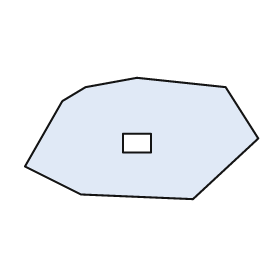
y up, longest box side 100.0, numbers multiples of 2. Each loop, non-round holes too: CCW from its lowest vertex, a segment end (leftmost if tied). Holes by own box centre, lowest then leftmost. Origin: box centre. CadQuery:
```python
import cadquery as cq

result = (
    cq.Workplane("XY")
    .moveTo(22.0, -26.0)
    .lineTo(50.0, 0.0)
    .lineTo(36.0, 22.0)
    .lineTo(-2.0, 26.0)
    .lineTo(-24.0, 22.0)
    .lineTo(-34.0, 16.0)
    .lineTo(-50.0, -12.0)
    .lineTo(-26.0, -24.0)
    .close()
    .moveTo(-8.0, -6.0)
    .lineTo(4.0, -6.0)
    .lineTo(4.0, 2.0)
    .lineTo(-8.0, 2.0)
    .close()
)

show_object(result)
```